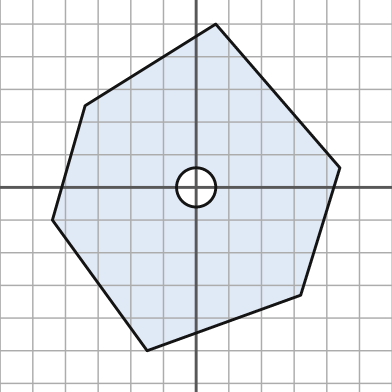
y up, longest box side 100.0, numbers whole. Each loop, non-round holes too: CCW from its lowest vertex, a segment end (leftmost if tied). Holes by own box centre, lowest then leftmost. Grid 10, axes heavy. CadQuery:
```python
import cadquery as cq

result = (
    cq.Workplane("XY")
    .moveTo(-15.0, -50.0)
    .lineTo(32.0, -33.0)
    .lineTo(44.0, 6.0)
    .lineTo(6.0, 50.0)
    .lineTo(-34.0, 25.0)
    .lineTo(-44.0, -10.0)
    .close()
    .moveTo(0.0, 0.0)
    .circle(6.0)
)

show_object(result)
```